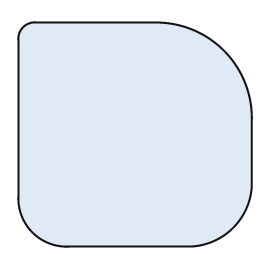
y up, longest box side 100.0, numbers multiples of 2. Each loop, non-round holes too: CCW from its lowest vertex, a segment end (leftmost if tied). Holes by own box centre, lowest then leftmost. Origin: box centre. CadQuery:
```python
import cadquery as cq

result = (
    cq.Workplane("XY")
    .moveTo(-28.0, -48.0)
    .lineTo(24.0, -48.0)
    .threePointArc((42.0, -40.0), (50.0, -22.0))
    .lineTo(50.0, 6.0)
    .threePointArc((38.0, 36.0), (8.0, 48.0))
    .lineTo(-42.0, 48.0)
    .threePointArc((-48.0, 46.0), (-50.0, 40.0))
    .lineTo(-50.0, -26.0)
    .threePointArc((-44.0, -42.0), (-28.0, -48.0))
    .close()
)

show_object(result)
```